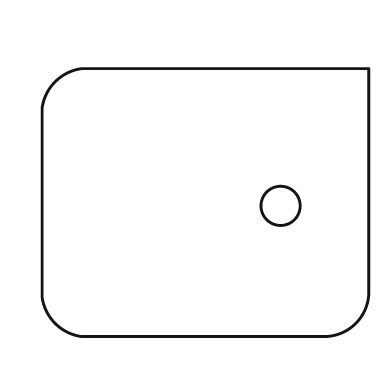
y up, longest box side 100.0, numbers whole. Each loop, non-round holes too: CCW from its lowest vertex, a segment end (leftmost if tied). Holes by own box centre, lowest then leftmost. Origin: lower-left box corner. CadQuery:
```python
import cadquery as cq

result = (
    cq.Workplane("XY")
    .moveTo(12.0, 0.0)
    .lineTo(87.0, 0.0)
    .threePointArc((96.0, 4.0), (100.0, 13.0))
    .lineTo(100.0, 82.0)
    .lineTo(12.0, 82.0)
    .threePointArc((4.0, 78.0), (0.0, 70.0))
    .lineTo(0.0, 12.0)
    .threePointArc((4.0, 4.0), (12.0, 0.0))
    .close()
    .moveTo(73.0, 40.0)
    .circle(6.0)
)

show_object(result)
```